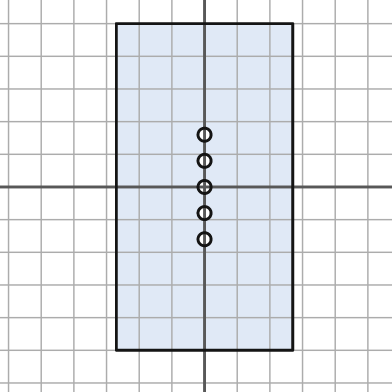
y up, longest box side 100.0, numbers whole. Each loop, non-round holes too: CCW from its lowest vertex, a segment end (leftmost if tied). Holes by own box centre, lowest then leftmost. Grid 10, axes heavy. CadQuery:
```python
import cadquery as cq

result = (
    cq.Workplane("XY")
    .moveTo(-27.0, -50.0)
    .lineTo(27.0, -50.0)
    .lineTo(27.0, 50.0)
    .lineTo(-27.0, 50.0)
    .close()
    .moveTo(0.0, -16.0)
    .circle(2.0)
    .moveTo(0.0, -8.0)
    .circle(2.0)
    .moveTo(0.0, 0.0)
    .circle(2.0)
    .moveTo(0.0, 8.0)
    .circle(2.0)
    .moveTo(0.0, 16.0)
    .circle(2.0)
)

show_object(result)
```